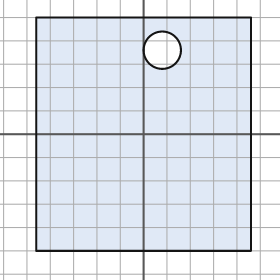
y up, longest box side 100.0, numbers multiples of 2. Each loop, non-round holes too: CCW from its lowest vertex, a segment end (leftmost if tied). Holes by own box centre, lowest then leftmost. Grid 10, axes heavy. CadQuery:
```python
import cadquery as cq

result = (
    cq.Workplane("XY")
    .moveTo(-46.0, -50.0)
    .lineTo(46.0, -50.0)
    .lineTo(46.0, 50.0)
    .lineTo(-46.0, 50.0)
    .close()
    .moveTo(8.0, 36.0)
    .circle(8.0)
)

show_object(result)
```